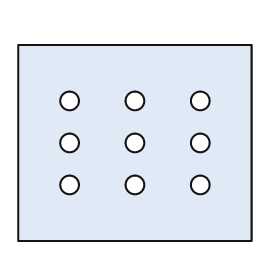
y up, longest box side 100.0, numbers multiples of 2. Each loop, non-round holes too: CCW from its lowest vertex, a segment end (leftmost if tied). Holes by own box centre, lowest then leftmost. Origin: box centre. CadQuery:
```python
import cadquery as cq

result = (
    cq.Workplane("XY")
    .moveTo(-50.0, -42.0)
    .lineTo(50.0, -42.0)
    .lineTo(50.0, 42.0)
    .lineTo(-50.0, 42.0)
    .close()
    .moveTo(-28.0, -18.0)
    .circle(4.0)
    .moveTo(0.0, -18.0)
    .circle(4.0)
    .moveTo(28.0, -18.0)
    .circle(4.0)
    .moveTo(-28.0, 0.0)
    .circle(4.0)
    .moveTo(0.0, 0.0)
    .circle(4.0)
    .moveTo(28.0, 0.0)
    .circle(4.0)
    .moveTo(-28.0, 18.0)
    .circle(4.0)
    .moveTo(0.0, 18.0)
    .circle(4.0)
    .moveTo(28.0, 18.0)
    .circle(4.0)
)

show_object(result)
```